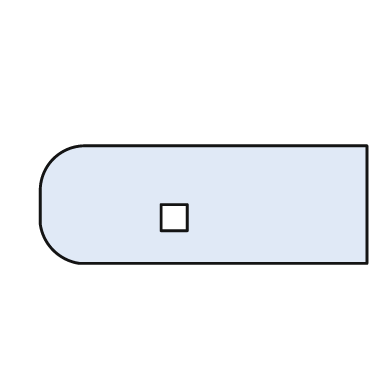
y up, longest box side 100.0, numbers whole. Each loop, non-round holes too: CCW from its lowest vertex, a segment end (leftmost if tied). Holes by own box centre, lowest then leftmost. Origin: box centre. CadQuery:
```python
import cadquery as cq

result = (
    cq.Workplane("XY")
    .moveTo(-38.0, -18.0)
    .lineTo(50.0, -18.0)
    .lineTo(50.0, 18.0)
    .lineTo(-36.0, 18.0)
    .threePointArc((-46.0, 14.0), (-50.0, 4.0))
    .lineTo(-50.0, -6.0)
    .threePointArc((-46.0, -14.0), (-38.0, -18.0))
    .close()
    .moveTo(-13.0, -8.0)
    .lineTo(-5.0, -8.0)
    .lineTo(-5.0, 0.0)
    .lineTo(-13.0, 0.0)
    .close()
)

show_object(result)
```